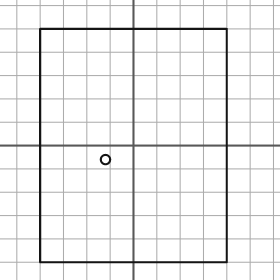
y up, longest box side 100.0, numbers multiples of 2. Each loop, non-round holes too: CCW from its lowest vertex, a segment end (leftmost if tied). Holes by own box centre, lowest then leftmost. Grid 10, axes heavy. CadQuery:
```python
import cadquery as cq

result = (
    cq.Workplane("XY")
    .moveTo(-40.0, -50.0)
    .lineTo(40.0, -50.0)
    .lineTo(40.0, 50.0)
    .lineTo(-40.0, 50.0)
    .close()
    .moveTo(-12.0, -6.0)
    .circle(2.0)
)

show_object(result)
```